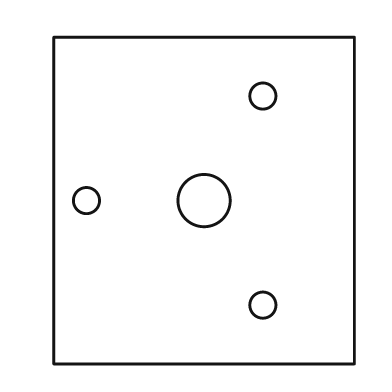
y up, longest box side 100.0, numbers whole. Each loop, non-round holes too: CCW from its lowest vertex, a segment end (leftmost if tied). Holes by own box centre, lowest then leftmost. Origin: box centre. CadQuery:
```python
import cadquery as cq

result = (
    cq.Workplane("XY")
    .moveTo(-46.0, -50.0)
    .lineTo(46.0, -50.0)
    .lineTo(46.0, 50.0)
    .lineTo(-46.0, 50.0)
    .close()
    .moveTo(18.0, -32.0)
    .circle(4.0)
    .moveTo(-36.0, 0.0)
    .circle(4.0)
    .moveTo(0.0, 0.0)
    .circle(8.0)
    .moveTo(18.0, 32.0)
    .circle(4.0)
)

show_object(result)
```